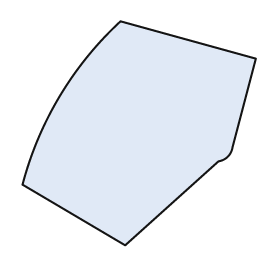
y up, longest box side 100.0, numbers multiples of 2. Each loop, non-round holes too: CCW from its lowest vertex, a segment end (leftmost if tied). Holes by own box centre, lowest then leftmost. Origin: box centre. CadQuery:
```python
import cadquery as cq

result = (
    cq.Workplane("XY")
    .moveTo(-6.0, -48.0)
    .lineTo(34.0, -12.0)
    .threePointArc((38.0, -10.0), (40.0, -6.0))
    .lineTo(50.0, 32.0)
    .lineTo(-8.0, 48.0)
    .threePointArc((-34.0, 16.0), (-50.0, -22.0))
    .close()
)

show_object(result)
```